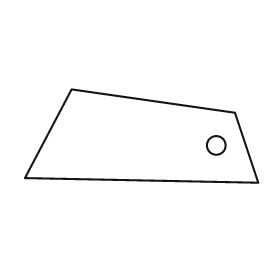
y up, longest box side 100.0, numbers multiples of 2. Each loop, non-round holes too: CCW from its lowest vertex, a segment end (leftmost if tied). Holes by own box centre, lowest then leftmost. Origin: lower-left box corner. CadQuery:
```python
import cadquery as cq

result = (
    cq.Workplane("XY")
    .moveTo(100.0, 0.0)
    .lineTo(90.0, 30.0)
    .lineTo(20.0, 40.0)
    .lineTo(0.0, 2.0)
    .close()
    .moveTo(82.0, 16.0)
    .circle(4.0)
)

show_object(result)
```